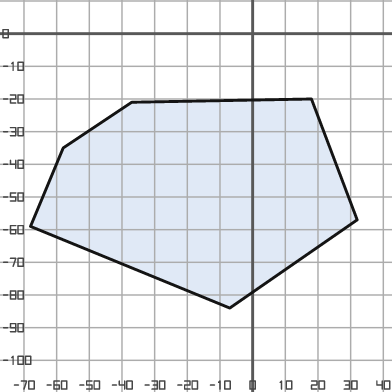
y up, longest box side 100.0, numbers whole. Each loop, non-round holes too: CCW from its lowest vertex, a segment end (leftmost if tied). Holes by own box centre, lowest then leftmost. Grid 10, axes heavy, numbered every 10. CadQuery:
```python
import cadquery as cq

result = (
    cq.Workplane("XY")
    .moveTo(-7.0, -84.0)
    .lineTo(32.0, -57.0)
    .lineTo(18.0, -20.0)
    .lineTo(-37.0, -21.0)
    .lineTo(-58.0, -35.0)
    .lineTo(-68.0, -59.0)
    .close()
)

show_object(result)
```